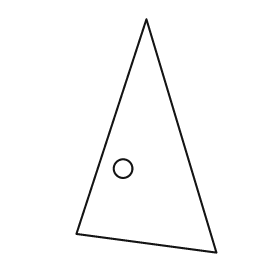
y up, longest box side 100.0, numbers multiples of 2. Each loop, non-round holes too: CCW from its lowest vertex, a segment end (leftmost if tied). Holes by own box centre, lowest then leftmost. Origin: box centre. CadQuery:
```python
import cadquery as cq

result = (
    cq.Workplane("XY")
    .moveTo(30.0, -50.0)
    .lineTo(0.0, 50.0)
    .lineTo(-30.0, -42.0)
    .close()
    .moveTo(-10.0, -14.0)
    .circle(4.0)
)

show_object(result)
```